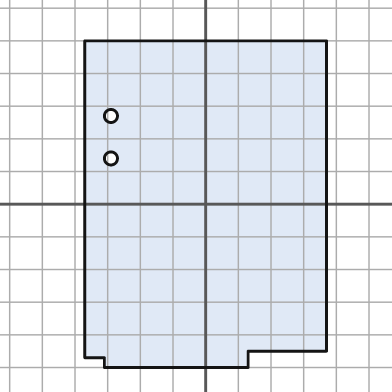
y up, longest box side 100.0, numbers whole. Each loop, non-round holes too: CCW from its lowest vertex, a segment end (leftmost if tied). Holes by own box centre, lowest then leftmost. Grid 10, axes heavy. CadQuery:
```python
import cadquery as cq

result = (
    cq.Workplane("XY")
    .moveTo(-31.0, -50.0)
    .lineTo(13.0, -50.0)
    .lineTo(13.0, -45.0)
    .lineTo(37.0, -45.0)
    .lineTo(37.0, 50.0)
    .lineTo(-37.0, 50.0)
    .lineTo(-37.0, -47.0)
    .lineTo(-31.0, -47.0)
    .close()
    .moveTo(-29.0, 14.0)
    .circle(2.0)
    .moveTo(-29.0, 27.0)
    .circle(2.0)
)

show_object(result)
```